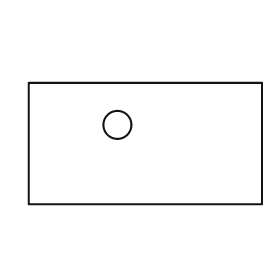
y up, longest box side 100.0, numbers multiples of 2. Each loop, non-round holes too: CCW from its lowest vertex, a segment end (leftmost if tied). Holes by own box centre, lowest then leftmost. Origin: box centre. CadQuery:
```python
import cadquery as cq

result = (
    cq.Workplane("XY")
    .moveTo(-50.0, -26.0)
    .lineTo(50.0, -26.0)
    .lineTo(50.0, 26.0)
    .lineTo(-50.0, 26.0)
    .close()
    .moveTo(-12.0, 8.0)
    .circle(6.0)
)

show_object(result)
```